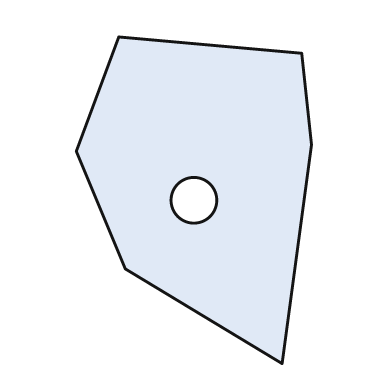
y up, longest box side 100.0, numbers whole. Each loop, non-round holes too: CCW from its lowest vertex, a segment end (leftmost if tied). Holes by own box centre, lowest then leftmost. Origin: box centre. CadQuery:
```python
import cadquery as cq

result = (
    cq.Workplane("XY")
    .moveTo(27.0, -50.0)
    .lineTo(36.0, 17.0)
    .lineTo(33.0, 45.0)
    .lineTo(-23.0, 50.0)
    .lineTo(-36.0, 15.0)
    .lineTo(-21.0, -21.0)
    .close()
    .moveTo(0.0, 0.0)
    .circle(7.0)
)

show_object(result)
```